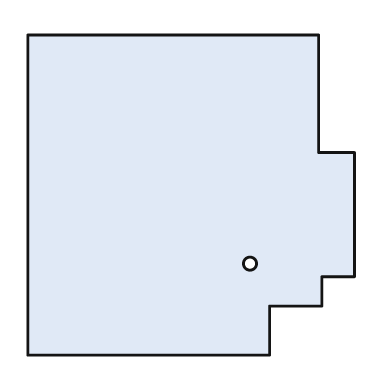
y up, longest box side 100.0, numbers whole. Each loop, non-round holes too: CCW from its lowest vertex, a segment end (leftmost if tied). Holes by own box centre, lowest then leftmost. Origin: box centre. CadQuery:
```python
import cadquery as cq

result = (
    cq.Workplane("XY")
    .moveTo(-50.0, -49.0)
    .lineTo(24.0, -49.0)
    .lineTo(24.0, -34.0)
    .lineTo(40.0, -34.0)
    .lineTo(40.0, -25.0)
    .lineTo(50.0, -25.0)
    .lineTo(50.0, 13.0)
    .lineTo(39.0, 13.0)
    .lineTo(39.0, 49.0)
    .lineTo(-50.0, 49.0)
    .close()
    .moveTo(18.0, -21.0)
    .circle(2.0)
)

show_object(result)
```